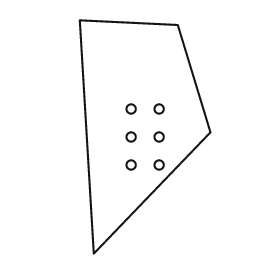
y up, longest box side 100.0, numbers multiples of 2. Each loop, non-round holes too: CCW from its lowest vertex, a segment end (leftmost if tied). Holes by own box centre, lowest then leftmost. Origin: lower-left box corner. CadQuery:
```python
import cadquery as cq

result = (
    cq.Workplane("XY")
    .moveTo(6.0, 0.0)
    .lineTo(56.0, 52.0)
    .lineTo(42.0, 98.0)
    .lineTo(0.0, 100.0)
    .close()
    .moveTo(22.0, 38.0)
    .circle(2.0)
    .moveTo(34.0, 38.0)
    .circle(2.0)
    .moveTo(22.0, 50.0)
    .circle(2.0)
    .moveTo(34.0, 50.0)
    .circle(2.0)
    .moveTo(22.0, 62.0)
    .circle(2.0)
    .moveTo(34.0, 62.0)
    .circle(2.0)
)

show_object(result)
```